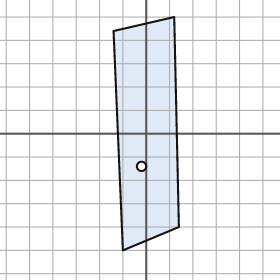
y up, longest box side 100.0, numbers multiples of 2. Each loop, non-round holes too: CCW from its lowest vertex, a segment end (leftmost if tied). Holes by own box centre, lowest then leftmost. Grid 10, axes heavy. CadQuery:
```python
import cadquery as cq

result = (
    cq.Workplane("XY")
    .moveTo(-10.0, -50.0)
    .lineTo(14.0, -40.0)
    .lineTo(12.0, 50.0)
    .lineTo(-14.0, 44.0)
    .close()
    .moveTo(-2.0, -14.0)
    .circle(2.0)
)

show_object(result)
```